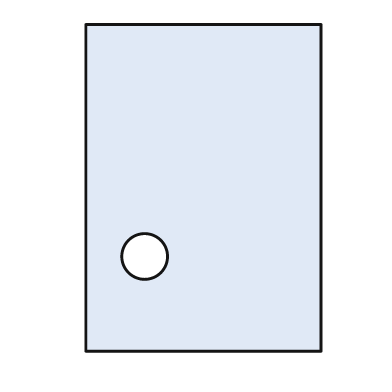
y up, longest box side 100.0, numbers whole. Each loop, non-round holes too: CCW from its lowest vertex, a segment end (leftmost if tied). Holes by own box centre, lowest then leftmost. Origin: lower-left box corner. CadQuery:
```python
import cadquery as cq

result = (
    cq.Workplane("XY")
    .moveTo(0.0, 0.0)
    .lineTo(72.0, 0.0)
    .lineTo(72.0, 100.0)
    .lineTo(0.0, 100.0)
    .close()
    .moveTo(18.0, 29.0)
    .circle(7.0)
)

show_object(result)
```